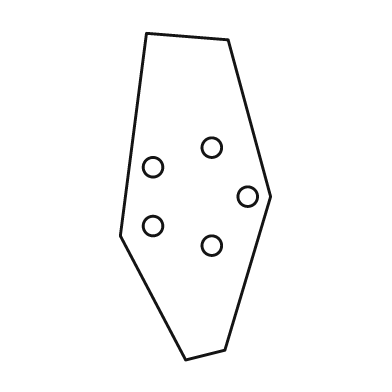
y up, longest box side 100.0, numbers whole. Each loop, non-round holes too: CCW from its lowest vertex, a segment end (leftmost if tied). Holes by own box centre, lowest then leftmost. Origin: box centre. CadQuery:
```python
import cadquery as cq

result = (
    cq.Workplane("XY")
    .moveTo(-3.0, -50.0)
    .lineTo(9.0, -47.0)
    .lineTo(23.0, 0.0)
    .lineTo(10.0, 48.0)
    .lineTo(-15.0, 50.0)
    .lineTo(-23.0, -12.0)
    .close()
    .moveTo(5.0, -15.0)
    .circle(3.0)
    .moveTo(-13.0, -9.0)
    .circle(3.0)
    .moveTo(16.0, 0.0)
    .circle(3.0)
    .moveTo(-13.0, 9.0)
    .circle(3.0)
    .moveTo(5.0, 15.0)
    .circle(3.0)
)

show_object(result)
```